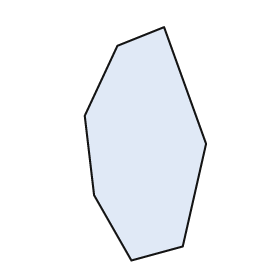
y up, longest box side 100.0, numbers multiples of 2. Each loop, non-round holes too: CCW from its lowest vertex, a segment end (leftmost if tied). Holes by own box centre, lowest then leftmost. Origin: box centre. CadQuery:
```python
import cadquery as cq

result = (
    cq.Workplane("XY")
    .moveTo(-6.0, -50.0)
    .lineTo(16.0, -44.0)
    .lineTo(26.0, 0.0)
    .lineTo(8.0, 50.0)
    .lineTo(-12.0, 42.0)
    .lineTo(-26.0, 12.0)
    .lineTo(-22.0, -22.0)
    .close()
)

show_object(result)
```